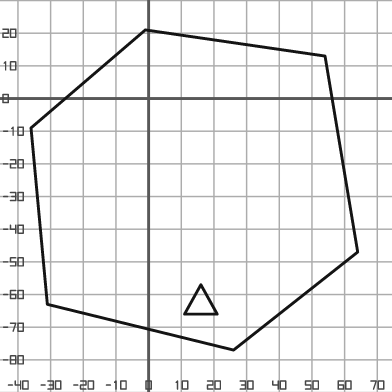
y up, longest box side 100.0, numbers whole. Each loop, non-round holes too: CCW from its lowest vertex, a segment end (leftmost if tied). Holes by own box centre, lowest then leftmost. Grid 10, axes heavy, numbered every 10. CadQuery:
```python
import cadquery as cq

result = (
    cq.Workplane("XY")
    .moveTo(26.0, -77.0)
    .lineTo(64.0, -47.0)
    .lineTo(54.0, 13.0)
    .lineTo(-1.0, 21.0)
    .lineTo(-36.0, -9.0)
    .lineTo(-31.0, -63.0)
    .close()
    .moveTo(11.0, -66.0)
    .lineTo(21.0, -66.0)
    .lineTo(16.0, -57.0)
    .close()
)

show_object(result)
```